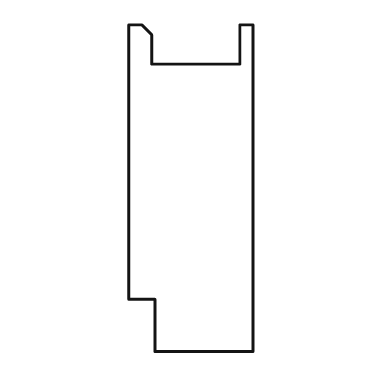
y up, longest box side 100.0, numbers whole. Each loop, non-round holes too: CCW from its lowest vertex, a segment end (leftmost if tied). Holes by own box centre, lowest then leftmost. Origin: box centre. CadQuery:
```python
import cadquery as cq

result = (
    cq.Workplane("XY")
    .moveTo(-11.0, -50.0)
    .lineTo(19.0, -50.0)
    .lineTo(19.0, 50.0)
    .lineTo(15.0, 50.0)
    .lineTo(15.0, 38.0)
    .lineTo(-12.0, 38.0)
    .lineTo(-12.0, 47.0)
    .lineTo(-15.0, 50.0)
    .lineTo(-19.0, 50.0)
    .lineTo(-19.0, -34.0)
    .lineTo(-11.0, -34.0)
    .close()
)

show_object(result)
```